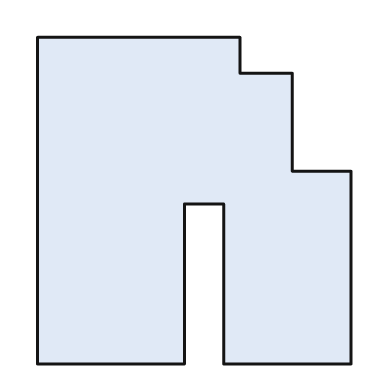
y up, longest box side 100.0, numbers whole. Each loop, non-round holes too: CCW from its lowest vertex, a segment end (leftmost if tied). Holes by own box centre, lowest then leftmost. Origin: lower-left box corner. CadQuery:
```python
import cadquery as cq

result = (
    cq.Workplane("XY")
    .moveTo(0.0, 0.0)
    .lineTo(45.0, 0.0)
    .lineTo(45.0, 49.0)
    .lineTo(57.0, 49.0)
    .lineTo(57.0, 0.0)
    .lineTo(96.0, 0.0)
    .lineTo(96.0, 59.0)
    .lineTo(78.0, 59.0)
    .lineTo(78.0, 89.0)
    .lineTo(62.0, 89.0)
    .lineTo(62.0, 100.0)
    .lineTo(0.0, 100.0)
    .close()
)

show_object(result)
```